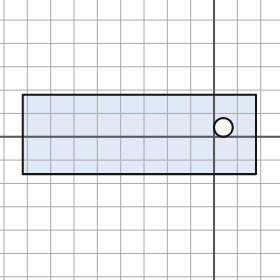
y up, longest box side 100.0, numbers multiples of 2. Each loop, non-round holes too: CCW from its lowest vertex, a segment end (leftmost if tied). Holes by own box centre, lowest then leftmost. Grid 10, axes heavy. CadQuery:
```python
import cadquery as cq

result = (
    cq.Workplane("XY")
    .moveTo(-82.0, -16.0)
    .lineTo(18.0, -16.0)
    .lineTo(18.0, 18.0)
    .lineTo(-82.0, 18.0)
    .close()
    .moveTo(4.0, 4.0)
    .circle(4.0)
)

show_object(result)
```